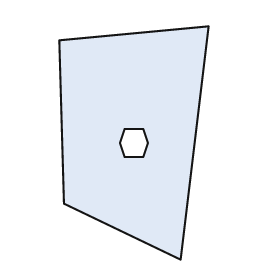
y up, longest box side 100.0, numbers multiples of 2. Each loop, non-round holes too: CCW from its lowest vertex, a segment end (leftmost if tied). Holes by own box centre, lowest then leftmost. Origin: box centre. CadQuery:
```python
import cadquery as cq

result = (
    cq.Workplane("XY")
    .moveTo(20.0, -50.0)
    .lineTo(32.0, 50.0)
    .lineTo(-32.0, 44.0)
    .lineTo(-30.0, -26.0)
    .close()
    .moveTo(-4.0, -6.0)
    .lineTo(4.0, -6.0)
    .lineTo(6.0, 0.0)
    .lineTo(4.0, 6.0)
    .lineTo(-4.0, 6.0)
    .lineTo(-6.0, 0.0)
    .close()
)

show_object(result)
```